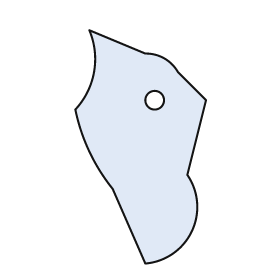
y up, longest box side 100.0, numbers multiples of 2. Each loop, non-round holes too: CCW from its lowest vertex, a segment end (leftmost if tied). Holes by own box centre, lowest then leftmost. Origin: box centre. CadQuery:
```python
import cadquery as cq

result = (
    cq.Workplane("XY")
    .moveTo(2.0, -50.0)
    .threePointArc((22.0, -36.0), (20.0, -12.0))
    .lineTo(28.0, 20.0)
    .lineTo(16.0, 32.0)
    .threePointArc((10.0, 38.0), (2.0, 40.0))
    .lineTo(-22.0, 50.0)
    .threePointArc((-20.0, 32.0), (-28.0, 16.0))
    .threePointArc((-22.0, -2.0), (-12.0, -18.0))
    .close()
    .moveTo(6.0, 20.0)
    .circle(4.0)
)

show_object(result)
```